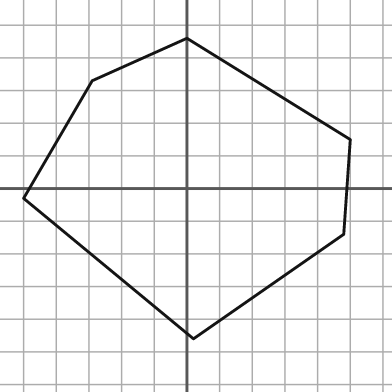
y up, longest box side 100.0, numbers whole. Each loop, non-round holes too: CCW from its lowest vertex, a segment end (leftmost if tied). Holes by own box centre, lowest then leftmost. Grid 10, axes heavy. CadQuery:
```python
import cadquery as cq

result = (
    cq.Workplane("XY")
    .moveTo(2.0, -46.0)
    .lineTo(48.0, -14.0)
    .lineTo(50.0, 15.0)
    .lineTo(0.0, 46.0)
    .lineTo(-29.0, 33.0)
    .lineTo(-50.0, -3.0)
    .close()
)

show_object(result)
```